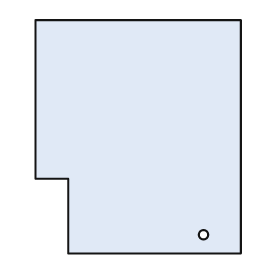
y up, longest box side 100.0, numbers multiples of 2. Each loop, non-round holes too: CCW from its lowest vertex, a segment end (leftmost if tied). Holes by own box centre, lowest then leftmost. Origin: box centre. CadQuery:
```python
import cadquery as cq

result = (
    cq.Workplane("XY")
    .moveTo(-30.0, -50.0)
    .lineTo(44.0, -50.0)
    .lineTo(44.0, 50.0)
    .lineTo(-44.0, 50.0)
    .lineTo(-44.0, -18.0)
    .lineTo(-30.0, -18.0)
    .close()
    .moveTo(28.0, -42.0)
    .circle(2.0)
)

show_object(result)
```